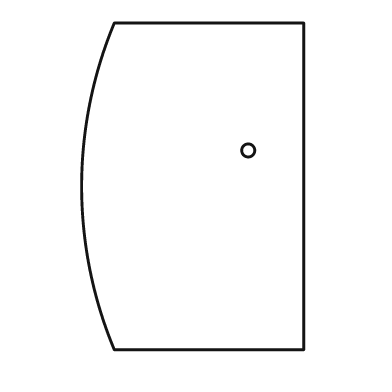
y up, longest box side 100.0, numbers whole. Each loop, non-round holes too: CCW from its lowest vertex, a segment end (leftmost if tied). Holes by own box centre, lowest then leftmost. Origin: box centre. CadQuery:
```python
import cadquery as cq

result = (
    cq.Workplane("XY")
    .moveTo(-24.0, -50.0)
    .lineTo(34.0, -50.0)
    .lineTo(34.0, 50.0)
    .lineTo(-24.0, 50.0)
    .threePointArc((-34.0, 0.0), (-24.0, -50.0))
    .close()
    .moveTo(17.0, 11.0)
    .circle(2.0)
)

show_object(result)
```